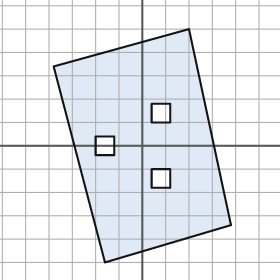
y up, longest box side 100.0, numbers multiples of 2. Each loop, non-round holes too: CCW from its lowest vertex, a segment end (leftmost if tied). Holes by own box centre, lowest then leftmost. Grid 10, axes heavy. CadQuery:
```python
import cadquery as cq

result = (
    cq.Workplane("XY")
    .moveTo(-16.0, -50.0)
    .lineTo(38.0, -34.0)
    .lineTo(20.0, 50.0)
    .lineTo(-38.0, 34.0)
    .close()
    .moveTo(4.0, -18.0)
    .lineTo(12.0, -18.0)
    .lineTo(12.0, -10.0)
    .lineTo(4.0, -10.0)
    .close()
    .moveTo(-20.0, -4.0)
    .lineTo(-12.0, -4.0)
    .lineTo(-12.0, 4.0)
    .lineTo(-20.0, 4.0)
    .close()
    .moveTo(4.0, 10.0)
    .lineTo(12.0, 10.0)
    .lineTo(12.0, 18.0)
    .lineTo(4.0, 18.0)
    .close()
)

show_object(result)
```